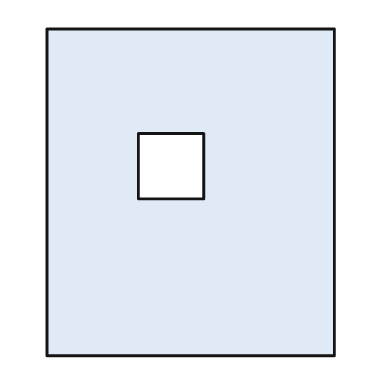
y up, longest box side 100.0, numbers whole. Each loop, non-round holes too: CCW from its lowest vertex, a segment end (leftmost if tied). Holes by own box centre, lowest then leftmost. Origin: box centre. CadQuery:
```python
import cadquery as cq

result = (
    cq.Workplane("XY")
    .moveTo(-44.0, -50.0)
    .lineTo(44.0, -50.0)
    .lineTo(44.0, 50.0)
    .lineTo(-44.0, 50.0)
    .close()
    .moveTo(-16.0, -2.0)
    .lineTo(4.0, -2.0)
    .lineTo(4.0, 18.0)
    .lineTo(-16.0, 18.0)
    .close()
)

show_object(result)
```